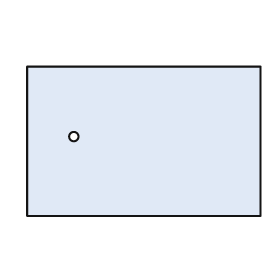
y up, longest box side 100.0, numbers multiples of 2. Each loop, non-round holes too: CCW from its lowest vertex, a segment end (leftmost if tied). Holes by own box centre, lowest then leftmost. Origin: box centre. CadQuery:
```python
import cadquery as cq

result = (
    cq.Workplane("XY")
    .moveTo(-50.0, -32.0)
    .lineTo(50.0, -32.0)
    .lineTo(50.0, 32.0)
    .lineTo(-50.0, 32.0)
    .close()
    .moveTo(-30.0, 2.0)
    .circle(2.0)
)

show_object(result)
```